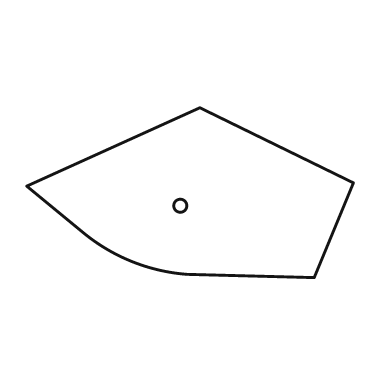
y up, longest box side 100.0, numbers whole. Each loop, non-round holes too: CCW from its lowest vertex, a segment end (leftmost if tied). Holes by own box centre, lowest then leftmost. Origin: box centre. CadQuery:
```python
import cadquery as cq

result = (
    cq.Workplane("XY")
    .moveTo(38.0, -26.0)
    .lineTo(50.0, 3.0)
    .lineTo(3.0, 26.0)
    .lineTo(-50.0, 2.0)
    .lineTo(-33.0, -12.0)
    .threePointArc((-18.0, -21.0), (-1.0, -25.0))
    .close()
    .moveTo(-3.0, -4.0)
    .circle(2.0)
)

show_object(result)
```